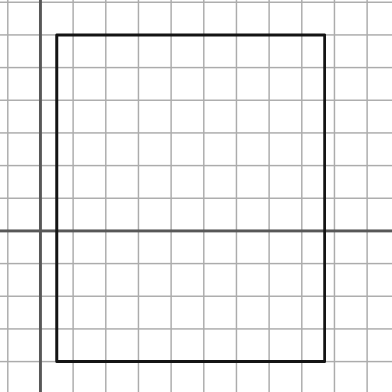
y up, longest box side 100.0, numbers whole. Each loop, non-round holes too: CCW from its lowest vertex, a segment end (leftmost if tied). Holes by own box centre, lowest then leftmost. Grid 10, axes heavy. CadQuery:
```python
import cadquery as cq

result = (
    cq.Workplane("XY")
    .moveTo(5.0, -40.0)
    .lineTo(87.0, -40.0)
    .lineTo(87.0, 60.0)
    .lineTo(5.0, 60.0)
    .close()
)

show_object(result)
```